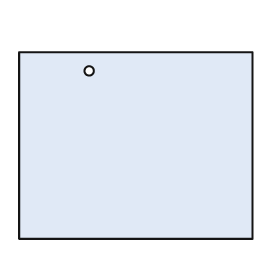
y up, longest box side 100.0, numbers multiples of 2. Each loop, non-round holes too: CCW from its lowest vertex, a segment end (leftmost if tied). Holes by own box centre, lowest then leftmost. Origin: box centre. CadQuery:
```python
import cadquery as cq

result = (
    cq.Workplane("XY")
    .moveTo(-50.0, -40.0)
    .lineTo(50.0, -40.0)
    .lineTo(50.0, 40.0)
    .lineTo(-50.0, 40.0)
    .close()
    .moveTo(-20.0, 32.0)
    .circle(2.0)
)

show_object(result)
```